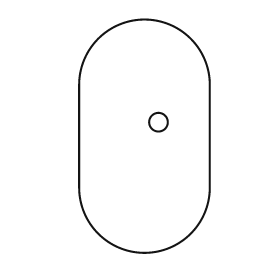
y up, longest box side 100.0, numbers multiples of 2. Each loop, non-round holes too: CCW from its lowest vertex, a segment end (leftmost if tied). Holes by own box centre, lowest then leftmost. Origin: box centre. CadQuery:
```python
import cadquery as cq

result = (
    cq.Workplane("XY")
    .moveTo(-28.0, -22.0)
    .threePointArc((0.0, -50.0), (28.0, -22.0))
    .lineTo(28.0, 22.0)
    .threePointArc((0.0, 50.0), (-28.0, 22.0))
    .close()
    .moveTo(6.0, 6.0)
    .circle(4.0)
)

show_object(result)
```